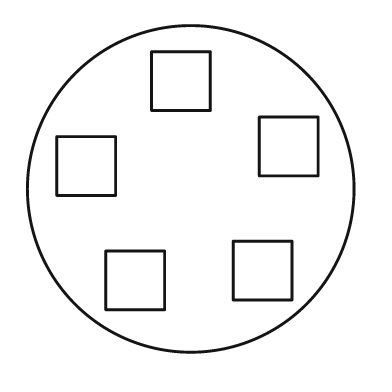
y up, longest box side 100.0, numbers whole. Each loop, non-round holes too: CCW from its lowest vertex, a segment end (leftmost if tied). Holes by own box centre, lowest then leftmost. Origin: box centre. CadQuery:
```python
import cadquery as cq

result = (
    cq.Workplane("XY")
    .moveTo(0.0, 0.0)
    .circle(50.0)
    .moveTo(-26.0, -37.0)
    .lineTo(-8.0, -37.0)
    .lineTo(-8.0, -19.0)
    .lineTo(-26.0, -19.0)
    .close()
    .moveTo(13.0, -34.0)
    .lineTo(31.0, -34.0)
    .lineTo(31.0, -16.0)
    .lineTo(13.0, -16.0)
    .close()
    .moveTo(-41.0, -2.0)
    .lineTo(-23.0, -2.0)
    .lineTo(-23.0, 16.0)
    .lineTo(-41.0, 16.0)
    .close()
    .moveTo(21.0, 4.0)
    .lineTo(39.0, 4.0)
    .lineTo(39.0, 22.0)
    .lineTo(21.0, 22.0)
    .close()
    .moveTo(-12.0, 24.0)
    .lineTo(6.0, 24.0)
    .lineTo(6.0, 42.0)
    .lineTo(-12.0, 42.0)
    .close()
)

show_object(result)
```